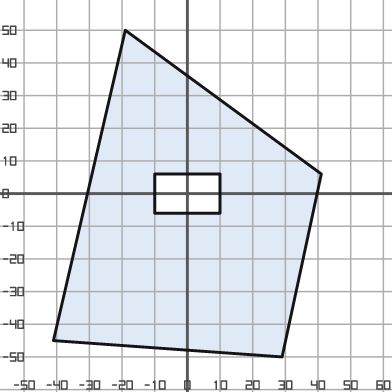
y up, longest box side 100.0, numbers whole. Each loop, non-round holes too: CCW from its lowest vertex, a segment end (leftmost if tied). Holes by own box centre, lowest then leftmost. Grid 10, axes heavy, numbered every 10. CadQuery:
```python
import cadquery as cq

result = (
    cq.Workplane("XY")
    .moveTo(29.0, -50.0)
    .lineTo(41.0, 6.0)
    .lineTo(-19.0, 50.0)
    .lineTo(-41.0, -45.0)
    .close()
    .moveTo(-10.0, -6.0)
    .lineTo(10.0, -6.0)
    .lineTo(10.0, 6.0)
    .lineTo(-10.0, 6.0)
    .close()
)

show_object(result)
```